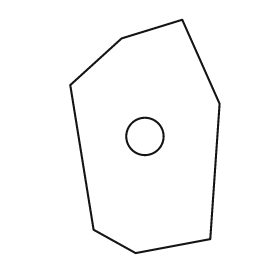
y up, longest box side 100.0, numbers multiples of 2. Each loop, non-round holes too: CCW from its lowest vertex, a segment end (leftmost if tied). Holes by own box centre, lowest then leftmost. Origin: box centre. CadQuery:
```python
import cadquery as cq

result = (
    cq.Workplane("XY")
    .moveTo(-4.0, -50.0)
    .lineTo(28.0, -44.0)
    .lineTo(32.0, 14.0)
    .lineTo(16.0, 50.0)
    .lineTo(-10.0, 42.0)
    .lineTo(-32.0, 22.0)
    .lineTo(-22.0, -40.0)
    .close()
    .moveTo(0.0, 0.0)
    .circle(8.0)
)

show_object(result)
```